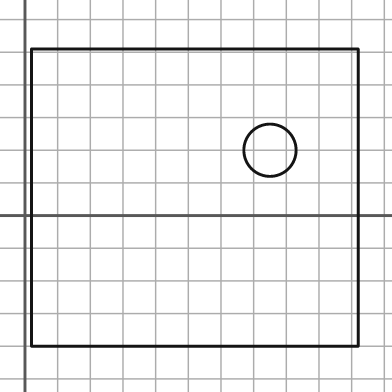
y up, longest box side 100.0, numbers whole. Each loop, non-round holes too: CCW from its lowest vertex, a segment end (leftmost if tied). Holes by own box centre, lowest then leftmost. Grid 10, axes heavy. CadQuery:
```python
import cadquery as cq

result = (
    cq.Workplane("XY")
    .moveTo(2.0, -40.0)
    .lineTo(102.0, -40.0)
    .lineTo(102.0, 51.0)
    .lineTo(2.0, 51.0)
    .close()
    .moveTo(75.0, 20.0)
    .circle(8.0)
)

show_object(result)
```